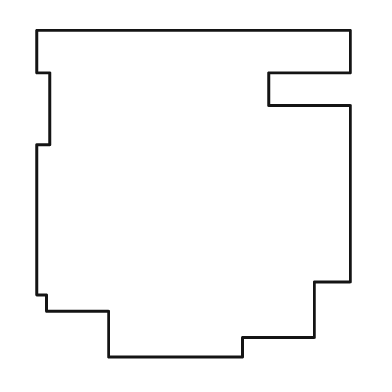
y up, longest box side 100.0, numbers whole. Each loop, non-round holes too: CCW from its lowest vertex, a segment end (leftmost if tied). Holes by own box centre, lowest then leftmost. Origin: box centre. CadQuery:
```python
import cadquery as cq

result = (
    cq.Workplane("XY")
    .moveTo(-26.0, -50.0)
    .lineTo(15.0, -50.0)
    .lineTo(15.0, -44.0)
    .lineTo(37.0, -44.0)
    .lineTo(37.0, -27.0)
    .lineTo(48.0, -27.0)
    .lineTo(48.0, 27.0)
    .lineTo(23.0, 27.0)
    .lineTo(23.0, 37.0)
    .lineTo(48.0, 37.0)
    .lineTo(48.0, 50.0)
    .lineTo(-48.0, 50.0)
    .lineTo(-48.0, 37.0)
    .lineTo(-44.0, 37.0)
    .lineTo(-44.0, 15.0)
    .lineTo(-48.0, 15.0)
    .lineTo(-48.0, -31.0)
    .lineTo(-45.0, -31.0)
    .lineTo(-45.0, -36.0)
    .lineTo(-26.0, -36.0)
    .close()
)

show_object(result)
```